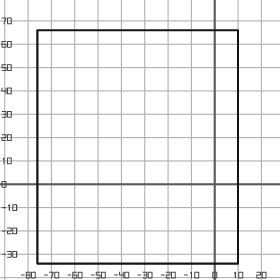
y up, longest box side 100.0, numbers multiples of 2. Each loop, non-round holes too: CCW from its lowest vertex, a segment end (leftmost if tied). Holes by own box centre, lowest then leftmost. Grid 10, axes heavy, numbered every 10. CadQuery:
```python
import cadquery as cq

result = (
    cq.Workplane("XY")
    .moveTo(-76.0, -34.0)
    .lineTo(10.0, -34.0)
    .lineTo(10.0, 66.0)
    .lineTo(-76.0, 66.0)
    .close()
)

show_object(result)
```